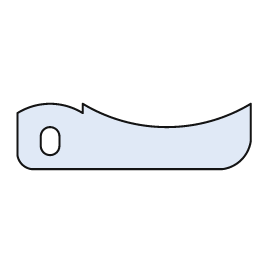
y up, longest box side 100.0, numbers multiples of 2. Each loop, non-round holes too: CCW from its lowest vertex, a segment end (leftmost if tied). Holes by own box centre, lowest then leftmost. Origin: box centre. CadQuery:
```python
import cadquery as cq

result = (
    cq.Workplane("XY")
    .moveTo(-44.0, -14.0)
    .lineTo(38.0, -14.0)
    .threePointArc((46.0, -10.0), (50.0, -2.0))
    .lineTo(50.0, 14.0)
    .threePointArc((14.0, 4.0), (-22.0, 14.0))
    .lineTo(-22.0, 10.0)
    .threePointArc((-36.0, 14.0), (-50.0, 10.0))
    .lineTo(-50.0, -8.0)
    .threePointArc((-48.0, -12.0), (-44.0, -14.0))
    .close()
    .moveTo(-40.0, -4.0)
    .threePointArc((-36.0, -8.0), (-32.0, -4.0))
    .lineTo(-32.0, 0.0)
    .threePointArc((-36.0, 4.0), (-40.0, 0.0))
    .close()
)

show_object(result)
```